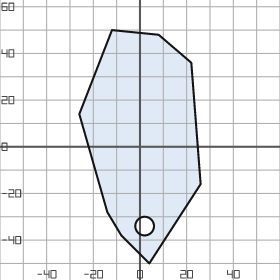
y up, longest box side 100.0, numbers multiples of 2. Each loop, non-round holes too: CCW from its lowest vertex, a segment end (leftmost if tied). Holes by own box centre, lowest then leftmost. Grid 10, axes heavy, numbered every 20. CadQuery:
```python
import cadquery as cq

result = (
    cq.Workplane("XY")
    .moveTo(4.0, -50.0)
    .lineTo(26.0, -16.0)
    .lineTo(22.0, 36.0)
    .lineTo(8.0, 48.0)
    .lineTo(-12.0, 50.0)
    .lineTo(-26.0, 14.0)
    .lineTo(-14.0, -28.0)
    .lineTo(-8.0, -38.0)
    .close()
    .moveTo(2.0, -34.0)
    .circle(4.0)
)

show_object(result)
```